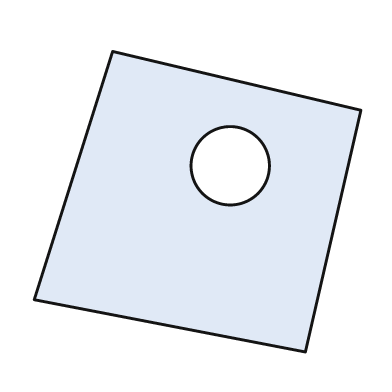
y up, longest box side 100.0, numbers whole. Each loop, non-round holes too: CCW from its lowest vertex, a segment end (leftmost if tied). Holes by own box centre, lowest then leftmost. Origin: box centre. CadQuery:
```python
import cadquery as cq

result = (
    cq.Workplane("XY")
    .moveTo(33.0, -46.0)
    .lineTo(50.0, 28.0)
    .lineTo(-26.0, 46.0)
    .lineTo(-50.0, -30.0)
    .close()
    .moveTo(10.0, 11.0)
    .circle(12.0)
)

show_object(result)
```